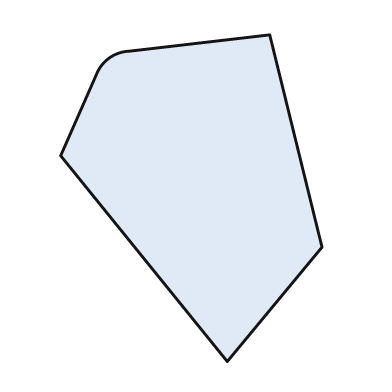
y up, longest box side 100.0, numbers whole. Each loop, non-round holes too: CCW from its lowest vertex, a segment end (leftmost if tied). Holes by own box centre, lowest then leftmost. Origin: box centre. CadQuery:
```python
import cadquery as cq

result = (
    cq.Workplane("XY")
    .moveTo(11.0, -50.0)
    .lineTo(40.0, -15.0)
    .lineTo(24.0, 50.0)
    .lineTo(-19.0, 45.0)
    .threePointArc((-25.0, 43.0), (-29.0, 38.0))
    .lineTo(-40.0, 13.0)
    .close()
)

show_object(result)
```